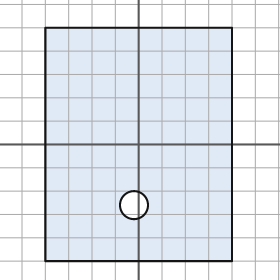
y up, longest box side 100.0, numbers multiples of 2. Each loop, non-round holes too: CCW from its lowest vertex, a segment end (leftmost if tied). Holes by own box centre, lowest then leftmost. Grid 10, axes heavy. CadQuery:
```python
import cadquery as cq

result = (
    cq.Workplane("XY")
    .moveTo(-40.0, -50.0)
    .lineTo(40.0, -50.0)
    .lineTo(40.0, 50.0)
    .lineTo(-40.0, 50.0)
    .close()
    .moveTo(-2.0, -26.0)
    .circle(6.0)
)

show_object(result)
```